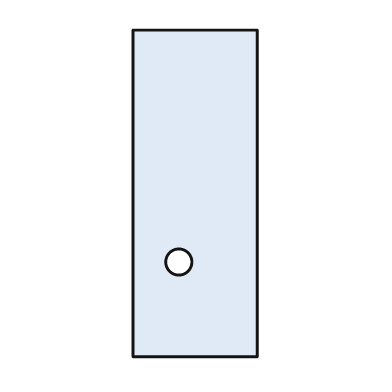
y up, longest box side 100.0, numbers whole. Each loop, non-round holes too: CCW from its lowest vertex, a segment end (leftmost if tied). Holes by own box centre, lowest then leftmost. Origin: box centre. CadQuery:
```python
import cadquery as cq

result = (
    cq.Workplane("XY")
    .moveTo(-19.0, -50.0)
    .lineTo(19.0, -50.0)
    .lineTo(19.0, 50.0)
    .lineTo(-19.0, 50.0)
    .close()
    .moveTo(-5.0, -21.0)
    .circle(4.0)
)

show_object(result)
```